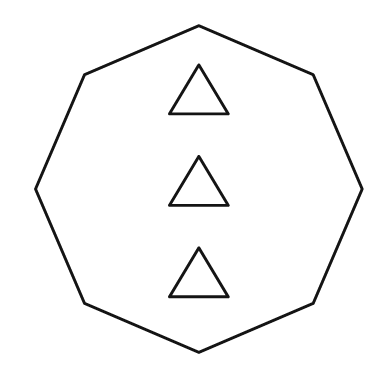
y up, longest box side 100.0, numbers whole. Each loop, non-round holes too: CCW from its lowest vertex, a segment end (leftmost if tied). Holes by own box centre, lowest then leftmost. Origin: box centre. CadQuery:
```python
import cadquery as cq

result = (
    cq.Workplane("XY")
    .moveTo(0.0, -50.0)
    .lineTo(35.0, -35.0)
    .lineTo(50.0, 0.0)
    .lineTo(35.0, 35.0)
    .lineTo(0.0, 50.0)
    .lineTo(-35.0, 35.0)
    .lineTo(-50.0, 0.0)
    .lineTo(-35.0, -35.0)
    .close()
    .moveTo(-9.0, -33.0)
    .lineTo(9.0, -33.0)
    .lineTo(0.0, -18.0)
    .close()
    .moveTo(-9.0, -5.0)
    .lineTo(9.0, -5.0)
    .lineTo(0.0, 10.0)
    .close()
    .moveTo(-9.0, 23.0)
    .lineTo(9.0, 23.0)
    .lineTo(0.0, 38.0)
    .close()
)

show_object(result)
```